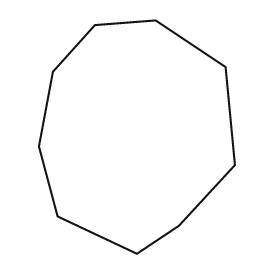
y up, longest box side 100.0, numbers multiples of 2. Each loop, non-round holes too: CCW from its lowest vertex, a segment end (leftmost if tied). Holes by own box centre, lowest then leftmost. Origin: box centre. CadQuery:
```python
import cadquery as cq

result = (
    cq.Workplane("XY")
    .moveTo(0.0, -50.0)
    .lineTo(18.0, -38.0)
    .lineTo(42.0, -12.0)
    .lineTo(38.0, 30.0)
    .lineTo(8.0, 50.0)
    .lineTo(-18.0, 48.0)
    .lineTo(-36.0, 28.0)
    .lineTo(-42.0, -4.0)
    .lineTo(-34.0, -34.0)
    .close()
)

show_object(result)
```